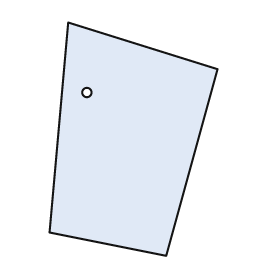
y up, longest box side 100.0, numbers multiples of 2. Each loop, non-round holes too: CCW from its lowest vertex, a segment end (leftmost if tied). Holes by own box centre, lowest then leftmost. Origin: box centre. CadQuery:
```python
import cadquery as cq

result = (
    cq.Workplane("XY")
    .moveTo(14.0, -50.0)
    .lineTo(36.0, 30.0)
    .lineTo(-28.0, 50.0)
    .lineTo(-36.0, -40.0)
    .close()
    .moveTo(-20.0, 20.0)
    .circle(2.0)
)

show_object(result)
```